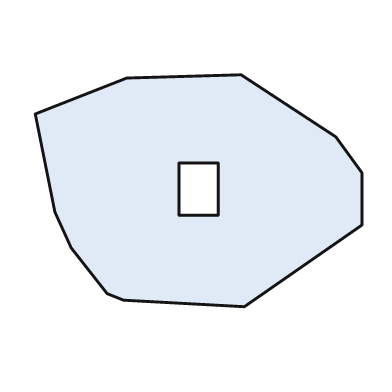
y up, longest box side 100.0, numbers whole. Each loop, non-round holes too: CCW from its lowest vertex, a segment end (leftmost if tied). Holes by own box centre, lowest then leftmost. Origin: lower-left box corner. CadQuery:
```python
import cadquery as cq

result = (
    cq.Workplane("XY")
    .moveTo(64.0, 0.0)
    .lineTo(100.0, 25.0)
    .lineTo(100.0, 41.0)
    .lineTo(92.0, 52.0)
    .lineTo(63.0, 71.0)
    .lineTo(28.0, 70.0)
    .lineTo(0.0, 59.0)
    .lineTo(6.0, 29.0)
    .lineTo(11.0, 18.0)
    .lineTo(22.0, 4.0)
    .lineTo(27.0, 2.0)
    .close()
    .moveTo(44.0, 28.0)
    .lineTo(56.0, 28.0)
    .lineTo(56.0, 44.0)
    .lineTo(44.0, 44.0)
    .close()
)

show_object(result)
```